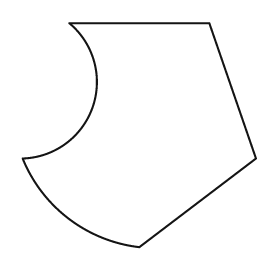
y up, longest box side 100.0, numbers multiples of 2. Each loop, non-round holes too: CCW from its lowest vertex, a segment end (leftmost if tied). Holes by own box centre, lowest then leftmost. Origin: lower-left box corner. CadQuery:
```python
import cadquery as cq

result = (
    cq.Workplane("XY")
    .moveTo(50.0, 0.0)
    .lineTo(100.0, 38.0)
    .lineTo(80.0, 96.0)
    .lineTo(20.0, 96.0)
    .threePointArc((30.0, 60.0), (0.0, 38.0))
    .threePointArc((20.0, 12.0), (50.0, 0.0))
    .close()
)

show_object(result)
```